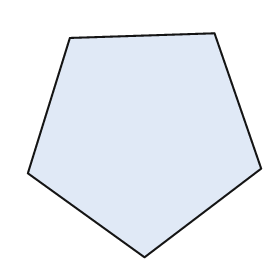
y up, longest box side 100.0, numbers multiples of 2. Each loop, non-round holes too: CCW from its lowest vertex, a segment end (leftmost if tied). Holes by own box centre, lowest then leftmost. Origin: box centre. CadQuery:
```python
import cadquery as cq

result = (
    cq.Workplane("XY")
    .moveTo(0.0, -48.0)
    .lineTo(50.0, -10.0)
    .lineTo(30.0, 48.0)
    .lineTo(-32.0, 46.0)
    .lineTo(-50.0, -12.0)
    .close()
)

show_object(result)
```